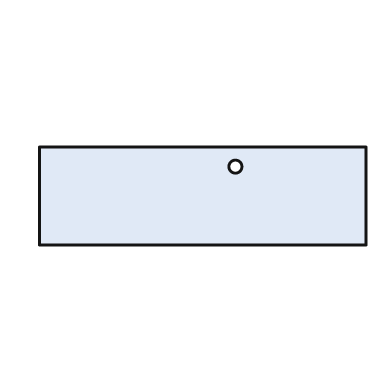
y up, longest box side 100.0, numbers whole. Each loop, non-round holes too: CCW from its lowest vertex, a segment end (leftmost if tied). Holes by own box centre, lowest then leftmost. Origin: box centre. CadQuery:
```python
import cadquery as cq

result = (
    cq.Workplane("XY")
    .moveTo(-50.0, -15.0)
    .lineTo(50.0, -15.0)
    .lineTo(50.0, 15.0)
    .lineTo(-50.0, 15.0)
    .close()
    .moveTo(10.0, 9.0)
    .circle(2.0)
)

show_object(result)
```